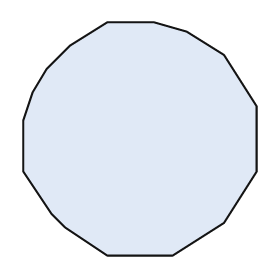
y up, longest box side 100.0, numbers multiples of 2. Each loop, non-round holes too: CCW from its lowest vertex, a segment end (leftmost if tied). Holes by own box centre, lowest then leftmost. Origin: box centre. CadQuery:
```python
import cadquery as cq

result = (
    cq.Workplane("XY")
    .moveTo(-14.0, -50.0)
    .lineTo(14.0, -50.0)
    .lineTo(36.0, -36.0)
    .lineTo(50.0, -14.0)
    .lineTo(50.0, 14.0)
    .lineTo(36.0, 36.0)
    .lineTo(20.0, 46.0)
    .lineTo(6.0, 50.0)
    .lineTo(-14.0, 50.0)
    .lineTo(-30.0, 40.0)
    .lineTo(-40.0, 30.0)
    .lineTo(-46.0, 20.0)
    .lineTo(-50.0, 8.0)
    .lineTo(-50.0, -14.0)
    .lineTo(-38.0, -32.0)
    .lineTo(-32.0, -38.0)
    .close()
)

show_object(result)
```